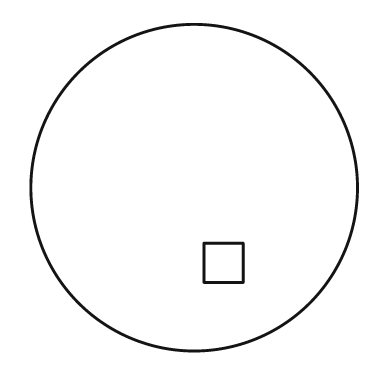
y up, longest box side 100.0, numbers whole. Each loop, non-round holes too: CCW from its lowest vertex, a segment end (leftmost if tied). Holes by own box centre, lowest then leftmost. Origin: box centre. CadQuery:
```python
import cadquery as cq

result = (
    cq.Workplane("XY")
    .moveTo(0.0, 0.0)
    .circle(50.0)
    .moveTo(3.0, -29.0)
    .lineTo(15.0, -29.0)
    .lineTo(15.0, -17.0)
    .lineTo(3.0, -17.0)
    .close()
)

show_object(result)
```